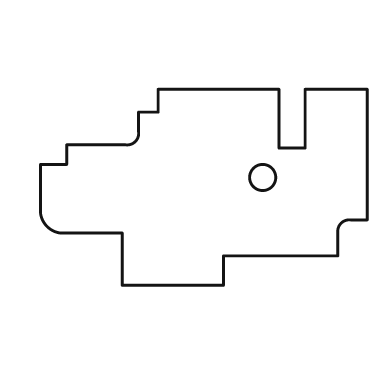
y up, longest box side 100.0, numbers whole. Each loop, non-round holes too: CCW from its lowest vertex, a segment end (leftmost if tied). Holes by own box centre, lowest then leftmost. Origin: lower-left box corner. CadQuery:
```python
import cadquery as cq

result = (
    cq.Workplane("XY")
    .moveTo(25.0, 0.0)
    .lineTo(56.0, 0.0)
    .lineTo(56.0, 9.0)
    .lineTo(91.0, 9.0)
    .lineTo(91.0, 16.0)
    .threePointArc((92.0, 19.0), (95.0, 20.0))
    .lineTo(100.0, 20.0)
    .lineTo(100.0, 60.0)
    .lineTo(81.0, 60.0)
    .lineTo(81.0, 42.0)
    .lineTo(73.0, 42.0)
    .lineTo(73.0, 60.0)
    .lineTo(36.0, 60.0)
    .lineTo(36.0, 53.0)
    .lineTo(30.0, 53.0)
    .lineTo(30.0, 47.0)
    .threePointArc((29.0, 44.0), (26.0, 43.0))
    .lineTo(8.0, 43.0)
    .lineTo(8.0, 37.0)
    .lineTo(0.0, 37.0)
    .lineTo(0.0, 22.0)
    .threePointArc((2.0, 18.0), (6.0, 16.0))
    .lineTo(25.0, 16.0)
    .close()
    .moveTo(68.0, 33.0)
    .circle(4.0)
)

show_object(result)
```